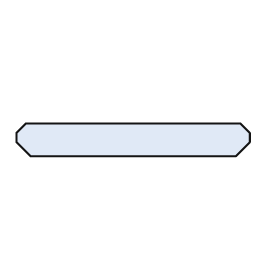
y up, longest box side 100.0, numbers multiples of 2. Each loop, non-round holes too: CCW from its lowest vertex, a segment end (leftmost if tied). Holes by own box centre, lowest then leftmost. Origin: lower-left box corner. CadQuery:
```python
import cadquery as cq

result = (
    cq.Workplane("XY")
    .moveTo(6.0, 0.0)
    .lineTo(94.0, 0.0)
    .lineTo(100.0, 6.0)
    .lineTo(100.0, 10.0)
    .lineTo(96.0, 14.0)
    .lineTo(4.0, 14.0)
    .lineTo(0.0, 10.0)
    .lineTo(0.0, 6.0)
    .close()
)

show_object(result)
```